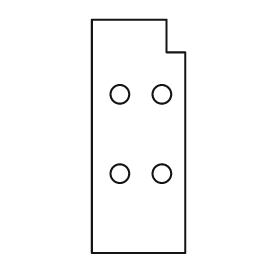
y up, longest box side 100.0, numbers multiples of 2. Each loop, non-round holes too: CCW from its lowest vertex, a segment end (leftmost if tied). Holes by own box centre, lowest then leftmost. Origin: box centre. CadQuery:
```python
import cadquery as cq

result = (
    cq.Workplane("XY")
    .moveTo(-20.0, -50.0)
    .lineTo(20.0, -50.0)
    .lineTo(20.0, 36.0)
    .lineTo(12.0, 36.0)
    .lineTo(12.0, 50.0)
    .lineTo(-20.0, 50.0)
    .close()
    .moveTo(-8.0, -16.0)
    .circle(4.0)
    .moveTo(10.0, -16.0)
    .circle(4.0)
    .moveTo(-8.0, 18.0)
    .circle(4.0)
    .moveTo(10.0, 18.0)
    .circle(4.0)
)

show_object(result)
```